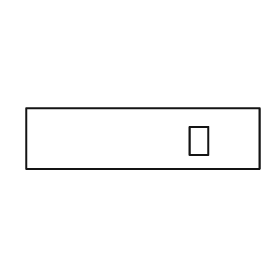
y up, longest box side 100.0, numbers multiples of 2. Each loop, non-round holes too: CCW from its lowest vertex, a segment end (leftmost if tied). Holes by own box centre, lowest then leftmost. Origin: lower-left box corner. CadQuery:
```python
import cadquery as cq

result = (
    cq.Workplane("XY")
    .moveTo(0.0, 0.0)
    .lineTo(100.0, 0.0)
    .lineTo(100.0, 26.0)
    .lineTo(0.0, 26.0)
    .close()
    .moveTo(70.0, 6.0)
    .lineTo(78.0, 6.0)
    .lineTo(78.0, 18.0)
    .lineTo(70.0, 18.0)
    .close()
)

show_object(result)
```